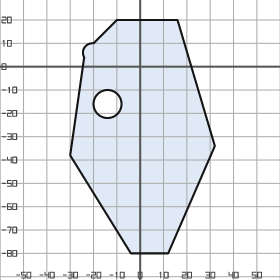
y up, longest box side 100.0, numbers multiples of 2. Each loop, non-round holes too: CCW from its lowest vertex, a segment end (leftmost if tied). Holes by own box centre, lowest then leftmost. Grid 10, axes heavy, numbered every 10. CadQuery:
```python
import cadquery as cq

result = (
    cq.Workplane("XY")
    .moveTo(-4.0, -80.0)
    .lineTo(12.0, -80.0)
    .lineTo(32.0, -34.0)
    .lineTo(16.0, 20.0)
    .lineTo(-10.0, 20.0)
    .lineTo(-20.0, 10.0)
    .threePointArc((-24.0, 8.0), (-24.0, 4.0))
    .lineTo(-30.0, -38.0)
    .close()
    .moveTo(-14.0, -16.0)
    .circle(6.0)
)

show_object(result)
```